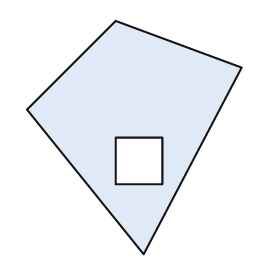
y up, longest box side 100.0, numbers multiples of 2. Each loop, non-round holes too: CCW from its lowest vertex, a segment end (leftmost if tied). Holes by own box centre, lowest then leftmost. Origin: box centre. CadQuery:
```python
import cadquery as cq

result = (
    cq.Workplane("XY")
    .moveTo(4.0, -50.0)
    .lineTo(46.0, 30.0)
    .lineTo(-8.0, 50.0)
    .lineTo(-46.0, 12.0)
    .close()
    .moveTo(-8.0, -20.0)
    .lineTo(12.0, -20.0)
    .lineTo(12.0, 0.0)
    .lineTo(-8.0, 0.0)
    .close()
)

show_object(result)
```